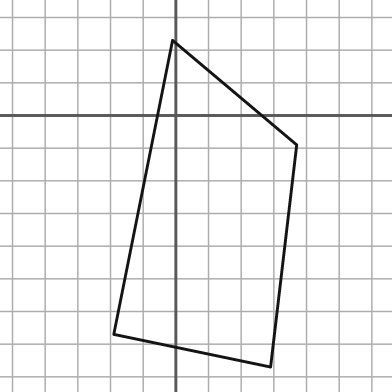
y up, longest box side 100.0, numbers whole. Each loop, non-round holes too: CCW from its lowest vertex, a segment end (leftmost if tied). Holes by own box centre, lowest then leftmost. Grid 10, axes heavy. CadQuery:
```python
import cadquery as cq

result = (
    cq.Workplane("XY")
    .moveTo(29.0, -77.0)
    .lineTo(37.0, -9.0)
    .lineTo(-1.0, 23.0)
    .lineTo(-19.0, -67.0)
    .close()
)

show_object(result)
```